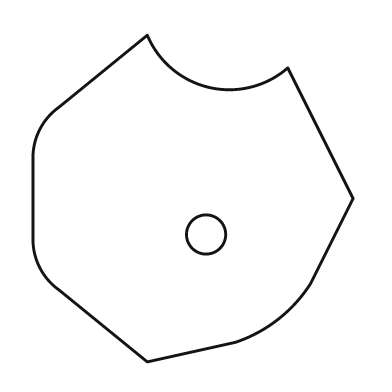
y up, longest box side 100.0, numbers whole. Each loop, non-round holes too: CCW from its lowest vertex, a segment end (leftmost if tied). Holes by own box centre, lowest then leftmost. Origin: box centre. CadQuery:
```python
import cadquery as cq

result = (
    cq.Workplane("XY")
    .moveTo(-14.0, -50.0)
    .lineTo(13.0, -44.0)
    .threePointArc((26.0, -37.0), (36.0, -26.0))
    .lineTo(49.0, 0.0)
    .lineTo(29.0, 40.0)
    .threePointArc((5.0, 34.0), (-14.0, 50.0))
    .lineTo(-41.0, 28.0)
    .threePointArc((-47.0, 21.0), (-49.0, 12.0))
    .lineTo(-49.0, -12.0)
    .threePointArc((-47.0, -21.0), (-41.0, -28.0))
    .close()
    .moveTo(4.0, -11.0)
    .circle(6.0)
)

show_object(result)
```